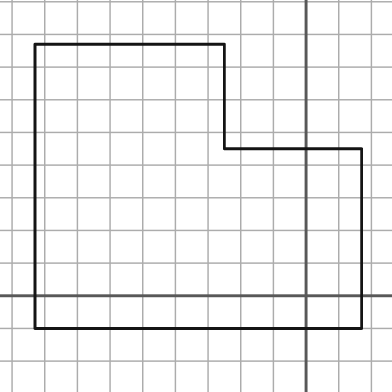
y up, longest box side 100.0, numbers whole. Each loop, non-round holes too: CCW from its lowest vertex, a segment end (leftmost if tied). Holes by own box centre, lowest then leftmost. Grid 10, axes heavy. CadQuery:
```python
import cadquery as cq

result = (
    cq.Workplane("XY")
    .moveTo(-83.0, -10.0)
    .lineTo(17.0, -10.0)
    .lineTo(17.0, 45.0)
    .lineTo(-25.0, 45.0)
    .lineTo(-25.0, 77.0)
    .lineTo(-83.0, 77.0)
    .close()
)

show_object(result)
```